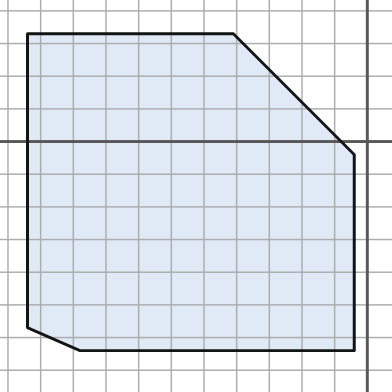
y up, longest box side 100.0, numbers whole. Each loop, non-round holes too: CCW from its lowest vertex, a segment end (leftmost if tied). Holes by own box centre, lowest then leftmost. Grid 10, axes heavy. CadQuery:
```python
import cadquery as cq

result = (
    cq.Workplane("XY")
    .moveTo(-88.0, -64.0)
    .lineTo(-4.0, -64.0)
    .lineTo(-4.0, -4.0)
    .lineTo(-41.0, 33.0)
    .lineTo(-104.0, 33.0)
    .lineTo(-104.0, -57.0)
    .close()
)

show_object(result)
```